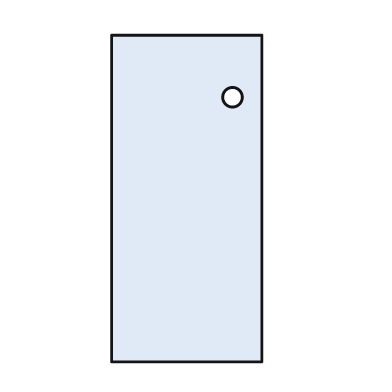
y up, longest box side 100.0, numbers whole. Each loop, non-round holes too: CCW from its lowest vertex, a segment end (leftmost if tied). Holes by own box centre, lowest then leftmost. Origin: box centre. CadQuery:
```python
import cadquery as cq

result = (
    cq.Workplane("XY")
    .moveTo(-23.0, -50.0)
    .lineTo(23.0, -50.0)
    .lineTo(23.0, 50.0)
    .lineTo(-23.0, 50.0)
    .close()
    .moveTo(14.0, 31.0)
    .circle(3.0)
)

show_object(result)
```